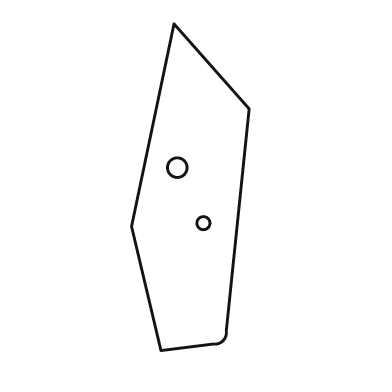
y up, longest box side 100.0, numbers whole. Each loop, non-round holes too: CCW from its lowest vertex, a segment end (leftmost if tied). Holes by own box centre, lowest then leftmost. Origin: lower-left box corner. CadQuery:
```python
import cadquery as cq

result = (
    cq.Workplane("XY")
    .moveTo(9.0, 0.0)
    .lineTo(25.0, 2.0)
    .threePointArc((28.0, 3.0), (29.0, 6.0))
    .lineTo(36.0, 74.0)
    .lineTo(13.0, 100.0)
    .lineTo(0.0, 38.0)
    .close()
    .moveTo(22.0, 39.0)
    .circle(2.0)
    .moveTo(14.0, 56.0)
    .circle(3.0)
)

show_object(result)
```